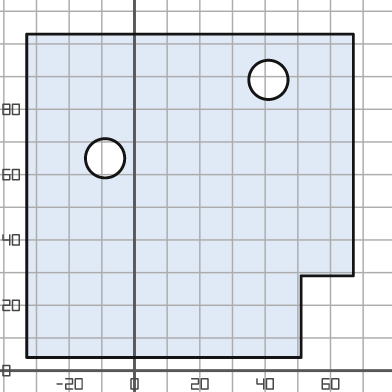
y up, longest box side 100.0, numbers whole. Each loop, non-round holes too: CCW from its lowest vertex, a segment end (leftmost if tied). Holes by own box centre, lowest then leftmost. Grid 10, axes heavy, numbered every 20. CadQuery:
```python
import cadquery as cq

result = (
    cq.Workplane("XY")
    .moveTo(-33.0, 4.0)
    .lineTo(51.0, 4.0)
    .lineTo(51.0, 29.0)
    .lineTo(67.0, 29.0)
    .lineTo(67.0, 103.0)
    .lineTo(-33.0, 103.0)
    .close()
    .moveTo(-9.0, 65.0)
    .circle(6.0)
    .moveTo(41.0, 89.0)
    .circle(6.0)
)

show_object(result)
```